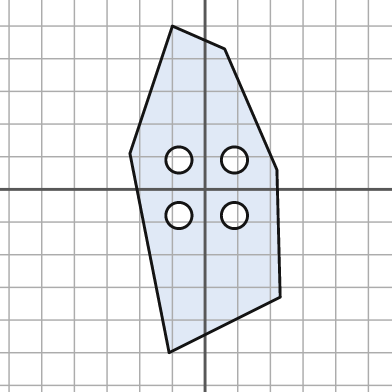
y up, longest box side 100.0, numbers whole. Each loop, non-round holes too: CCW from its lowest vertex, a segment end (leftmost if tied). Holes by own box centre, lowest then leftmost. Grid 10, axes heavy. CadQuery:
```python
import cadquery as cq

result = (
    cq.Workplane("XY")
    .moveTo(-11.0, -50.0)
    .lineTo(23.0, -33.0)
    .lineTo(22.0, 6.0)
    .lineTo(6.0, 43.0)
    .lineTo(-10.0, 50.0)
    .lineTo(-23.0, 11.0)
    .close()
    .moveTo(-8.0, -8.0)
    .circle(4.0)
    .moveTo(9.0, -8.0)
    .circle(4.0)
    .moveTo(-8.0, 9.0)
    .circle(4.0)
    .moveTo(9.0, 9.0)
    .circle(4.0)
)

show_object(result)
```